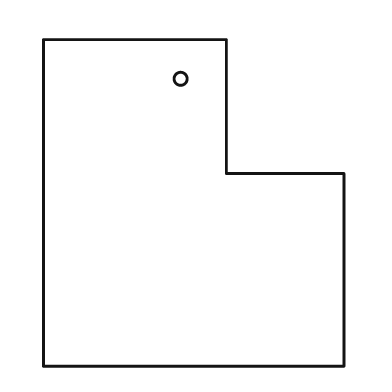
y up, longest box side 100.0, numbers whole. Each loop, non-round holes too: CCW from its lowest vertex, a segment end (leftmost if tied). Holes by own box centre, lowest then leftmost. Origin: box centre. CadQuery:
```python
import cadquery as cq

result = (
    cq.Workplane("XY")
    .moveTo(-46.0, -50.0)
    .lineTo(46.0, -50.0)
    .lineTo(46.0, 9.0)
    .lineTo(10.0, 9.0)
    .lineTo(10.0, 50.0)
    .lineTo(-46.0, 50.0)
    .close()
    .moveTo(-4.0, 38.0)
    .circle(2.0)
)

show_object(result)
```